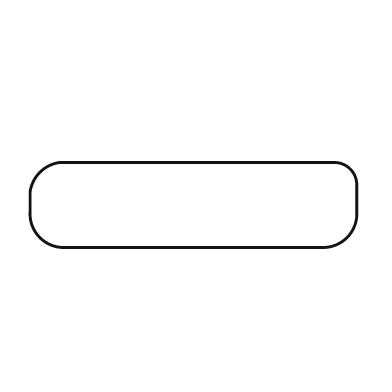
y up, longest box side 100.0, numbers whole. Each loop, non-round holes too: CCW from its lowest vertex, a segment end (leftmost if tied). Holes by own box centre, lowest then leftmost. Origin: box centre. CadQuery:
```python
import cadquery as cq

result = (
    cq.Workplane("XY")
    .moveTo(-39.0, -13.0)
    .lineTo(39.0, -13.0)
    .threePointArc((47.0, -10.0), (50.0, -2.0))
    .lineTo(50.0, 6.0)
    .threePointArc((48.0, 11.0), (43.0, 13.0))
    .lineTo(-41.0, 13.0)
    .threePointArc((-47.0, 10.0), (-50.0, 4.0))
    .lineTo(-50.0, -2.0)
    .threePointArc((-47.0, -10.0), (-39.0, -13.0))
    .close()
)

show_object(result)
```